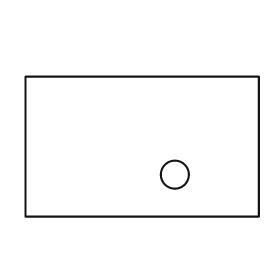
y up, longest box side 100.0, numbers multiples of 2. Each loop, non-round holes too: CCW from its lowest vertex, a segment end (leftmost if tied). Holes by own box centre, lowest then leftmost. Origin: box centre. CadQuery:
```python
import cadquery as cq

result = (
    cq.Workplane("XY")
    .moveTo(-50.0, -30.0)
    .lineTo(50.0, -30.0)
    .lineTo(50.0, 30.0)
    .lineTo(-50.0, 30.0)
    .close()
    .moveTo(14.0, -12.0)
    .circle(6.0)
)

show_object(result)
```